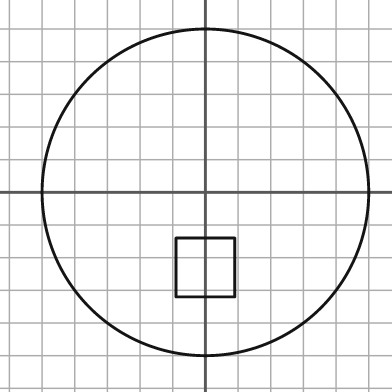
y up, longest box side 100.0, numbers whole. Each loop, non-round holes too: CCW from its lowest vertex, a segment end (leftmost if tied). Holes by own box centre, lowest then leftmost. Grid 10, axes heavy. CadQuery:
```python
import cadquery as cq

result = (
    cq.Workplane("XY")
    .moveTo(0.0, 0.0)
    .circle(50.0)
    .moveTo(-9.0, -32.0)
    .lineTo(9.0, -32.0)
    .lineTo(9.0, -14.0)
    .lineTo(-9.0, -14.0)
    .close()
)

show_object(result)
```